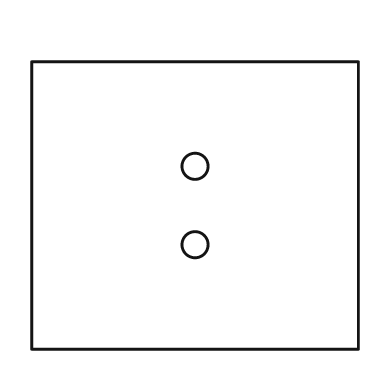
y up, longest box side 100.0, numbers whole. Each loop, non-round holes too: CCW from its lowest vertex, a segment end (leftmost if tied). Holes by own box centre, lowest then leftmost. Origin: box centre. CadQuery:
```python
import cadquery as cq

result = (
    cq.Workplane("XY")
    .moveTo(-50.0, -44.0)
    .lineTo(50.0, -44.0)
    .lineTo(50.0, 44.0)
    .lineTo(-50.0, 44.0)
    .close()
    .moveTo(0.0, -12.0)
    .circle(4.0)
    .moveTo(0.0, 12.0)
    .circle(4.0)
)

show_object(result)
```